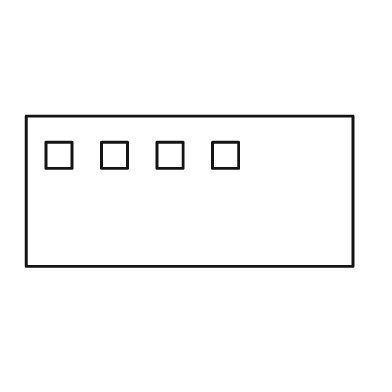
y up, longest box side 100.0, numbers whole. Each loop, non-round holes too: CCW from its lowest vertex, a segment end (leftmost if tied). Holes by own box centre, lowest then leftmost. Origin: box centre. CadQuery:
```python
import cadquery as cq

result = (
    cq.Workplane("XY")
    .moveTo(-50.0, -23.0)
    .lineTo(50.0, -23.0)
    .lineTo(50.0, 23.0)
    .lineTo(-50.0, 23.0)
    .close()
    .moveTo(-44.0, 7.0)
    .lineTo(-36.0, 7.0)
    .lineTo(-36.0, 15.0)
    .lineTo(-44.0, 15.0)
    .close()
    .moveTo(-27.0, 7.0)
    .lineTo(-19.0, 7.0)
    .lineTo(-19.0, 15.0)
    .lineTo(-27.0, 15.0)
    .close()
    .moveTo(-10.0, 7.0)
    .lineTo(-2.0, 7.0)
    .lineTo(-2.0, 15.0)
    .lineTo(-10.0, 15.0)
    .close()
    .moveTo(7.0, 7.0)
    .lineTo(15.0, 7.0)
    .lineTo(15.0, 15.0)
    .lineTo(7.0, 15.0)
    .close()
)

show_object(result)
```